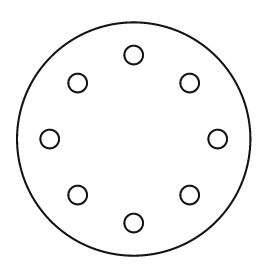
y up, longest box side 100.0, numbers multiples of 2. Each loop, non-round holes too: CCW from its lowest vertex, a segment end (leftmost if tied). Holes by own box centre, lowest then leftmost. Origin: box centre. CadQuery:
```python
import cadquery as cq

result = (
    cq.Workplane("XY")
    .moveTo(0.0, 0.0)
    .circle(50.0)
    .moveTo(0.0, -36.0)
    .circle(4.0)
    .moveTo(-24.0, -24.0)
    .circle(4.0)
    .moveTo(24.0, -24.0)
    .circle(4.0)
    .moveTo(-36.0, 0.0)
    .circle(4.0)
    .moveTo(36.0, 0.0)
    .circle(4.0)
    .moveTo(-24.0, 24.0)
    .circle(4.0)
    .moveTo(24.0, 24.0)
    .circle(4.0)
    .moveTo(0.0, 36.0)
    .circle(4.0)
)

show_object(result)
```